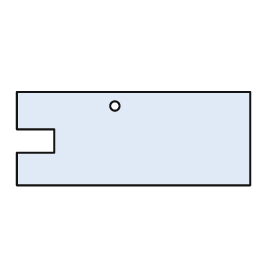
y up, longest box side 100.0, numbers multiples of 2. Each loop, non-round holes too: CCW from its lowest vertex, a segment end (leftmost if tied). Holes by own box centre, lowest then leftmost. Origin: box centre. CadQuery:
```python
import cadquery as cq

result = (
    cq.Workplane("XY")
    .moveTo(-50.0, -20.0)
    .lineTo(50.0, -20.0)
    .lineTo(50.0, 20.0)
    .lineTo(-50.0, 20.0)
    .lineTo(-50.0, 4.0)
    .lineTo(-34.0, 4.0)
    .lineTo(-34.0, -6.0)
    .lineTo(-50.0, -6.0)
    .close()
    .moveTo(-8.0, 14.0)
    .circle(2.0)
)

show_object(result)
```